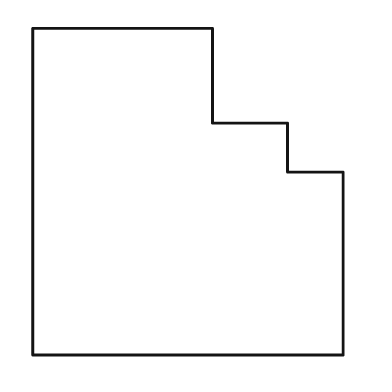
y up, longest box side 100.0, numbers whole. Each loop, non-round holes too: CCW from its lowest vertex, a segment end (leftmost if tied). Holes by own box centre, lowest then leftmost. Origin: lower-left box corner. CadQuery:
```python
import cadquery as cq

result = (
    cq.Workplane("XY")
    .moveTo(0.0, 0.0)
    .lineTo(95.0, 0.0)
    .lineTo(95.0, 56.0)
    .lineTo(78.0, 56.0)
    .lineTo(78.0, 71.0)
    .lineTo(55.0, 71.0)
    .lineTo(55.0, 100.0)
    .lineTo(0.0, 100.0)
    .close()
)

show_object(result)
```